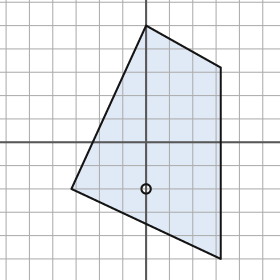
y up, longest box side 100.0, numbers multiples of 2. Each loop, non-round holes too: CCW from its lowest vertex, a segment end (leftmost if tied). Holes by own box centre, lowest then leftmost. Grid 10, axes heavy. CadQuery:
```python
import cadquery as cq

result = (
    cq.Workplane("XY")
    .moveTo(32.0, -50.0)
    .lineTo(32.0, 32.0)
    .lineTo(0.0, 50.0)
    .lineTo(-32.0, -20.0)
    .close()
    .moveTo(0.0, -20.0)
    .circle(2.0)
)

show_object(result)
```